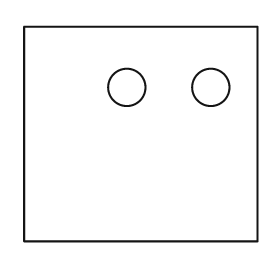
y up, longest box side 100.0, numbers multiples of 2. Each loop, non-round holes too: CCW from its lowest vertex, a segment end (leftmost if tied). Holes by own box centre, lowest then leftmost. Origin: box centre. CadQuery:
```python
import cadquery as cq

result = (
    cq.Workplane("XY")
    .moveTo(-50.0, -46.0)
    .lineTo(50.0, -46.0)
    .lineTo(50.0, 46.0)
    .lineTo(-50.0, 46.0)
    .close()
    .moveTo(-6.0, 20.0)
    .circle(8.0)
    .moveTo(30.0, 20.0)
    .circle(8.0)
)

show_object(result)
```